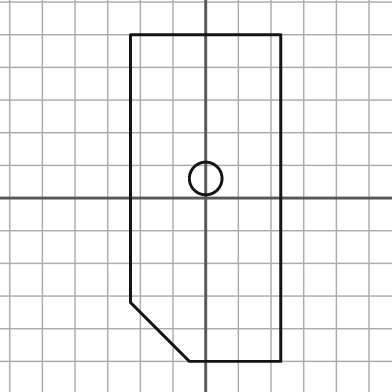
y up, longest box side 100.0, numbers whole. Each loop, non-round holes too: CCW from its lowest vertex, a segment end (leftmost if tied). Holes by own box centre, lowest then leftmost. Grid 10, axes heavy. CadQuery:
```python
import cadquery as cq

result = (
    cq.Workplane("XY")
    .moveTo(-5.0, -50.0)
    .lineTo(23.0, -50.0)
    .lineTo(23.0, 50.0)
    .lineTo(-23.0, 50.0)
    .lineTo(-23.0, -32.0)
    .close()
    .moveTo(0.0, 6.0)
    .circle(5.0)
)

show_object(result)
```